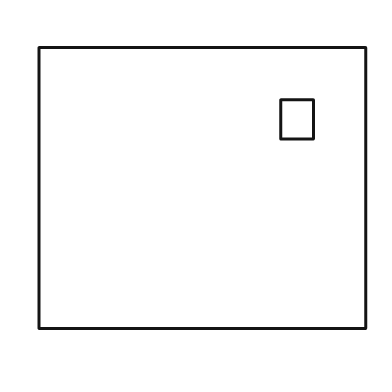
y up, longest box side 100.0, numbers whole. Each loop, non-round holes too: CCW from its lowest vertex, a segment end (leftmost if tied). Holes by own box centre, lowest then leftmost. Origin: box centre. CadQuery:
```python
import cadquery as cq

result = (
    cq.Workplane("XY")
    .moveTo(-50.0, -43.0)
    .lineTo(50.0, -43.0)
    .lineTo(50.0, 43.0)
    .lineTo(-50.0, 43.0)
    .close()
    .moveTo(24.0, 15.0)
    .lineTo(34.0, 15.0)
    .lineTo(34.0, 27.0)
    .lineTo(24.0, 27.0)
    .close()
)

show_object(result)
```